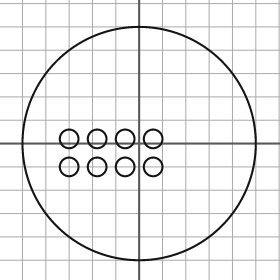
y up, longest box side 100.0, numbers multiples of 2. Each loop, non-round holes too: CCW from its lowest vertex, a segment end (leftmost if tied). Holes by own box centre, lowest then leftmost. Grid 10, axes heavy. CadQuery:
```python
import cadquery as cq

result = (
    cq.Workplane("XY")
    .moveTo(0.0, 0.0)
    .circle(50.0)
    .moveTo(-30.0, -10.0)
    .circle(4.0)
    .moveTo(-18.0, -10.0)
    .circle(4.0)
    .moveTo(-6.0, -10.0)
    .circle(4.0)
    .moveTo(6.0, -10.0)
    .circle(4.0)
    .moveTo(-30.0, 2.0)
    .circle(4.0)
    .moveTo(-18.0, 2.0)
    .circle(4.0)
    .moveTo(-6.0, 2.0)
    .circle(4.0)
    .moveTo(6.0, 2.0)
    .circle(4.0)
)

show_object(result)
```